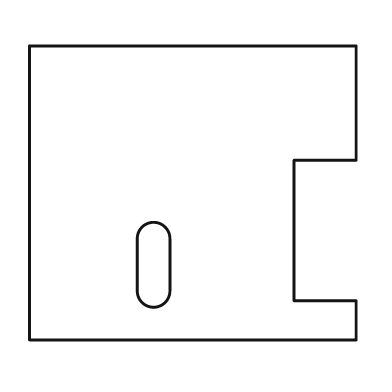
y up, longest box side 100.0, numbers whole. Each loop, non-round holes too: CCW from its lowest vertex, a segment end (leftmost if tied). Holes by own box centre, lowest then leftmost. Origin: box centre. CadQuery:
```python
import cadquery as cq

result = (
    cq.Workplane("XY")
    .moveTo(-50.0, -45.0)
    .lineTo(50.0, -45.0)
    .lineTo(50.0, -33.0)
    .lineTo(31.0, -33.0)
    .lineTo(31.0, 10.0)
    .lineTo(50.0, 10.0)
    .lineTo(50.0, 45.0)
    .lineTo(-50.0, 45.0)
    .close()
    .moveTo(-17.0, -30.0)
    .threePointArc((-12.0, -35.0), (-7.0, -30.0))
    .lineTo(-7.0, -14.0)
    .threePointArc((-12.0, -9.0), (-17.0, -14.0))
    .close()
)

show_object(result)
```